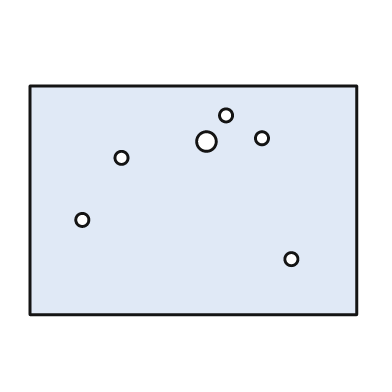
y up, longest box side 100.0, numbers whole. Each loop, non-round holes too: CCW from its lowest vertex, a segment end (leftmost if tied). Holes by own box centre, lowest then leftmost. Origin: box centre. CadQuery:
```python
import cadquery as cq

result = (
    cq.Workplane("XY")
    .moveTo(-50.0, -35.0)
    .lineTo(50.0, -35.0)
    .lineTo(50.0, 35.0)
    .lineTo(-50.0, 35.0)
    .close()
    .moveTo(30.0, -18.0)
    .circle(2.0)
    .moveTo(-34.0, -6.0)
    .circle(2.0)
    .moveTo(-22.0, 13.0)
    .circle(2.0)
    .moveTo(4.0, 18.0)
    .circle(3.0)
    .moveTo(21.0, 19.0)
    .circle(2.0)
    .moveTo(10.0, 26.0)
    .circle(2.0)
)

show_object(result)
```